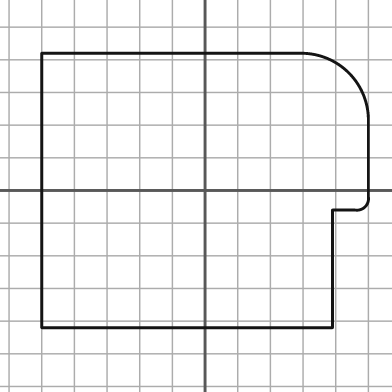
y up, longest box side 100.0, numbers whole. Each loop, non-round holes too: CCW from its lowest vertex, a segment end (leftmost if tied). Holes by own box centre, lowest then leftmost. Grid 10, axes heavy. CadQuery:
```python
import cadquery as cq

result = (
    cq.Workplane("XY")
    .moveTo(-50.0, -42.0)
    .lineTo(39.0, -42.0)
    .lineTo(39.0, -6.0)
    .lineTo(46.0, -6.0)
    .threePointArc((49.0, -5.0), (50.0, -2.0))
    .lineTo(50.0, 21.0)
    .threePointArc((44.0, 36.0), (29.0, 42.0))
    .lineTo(-50.0, 42.0)
    .close()
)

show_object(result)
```